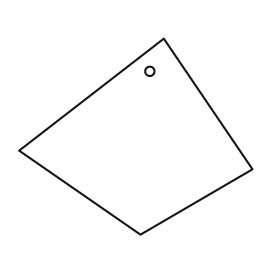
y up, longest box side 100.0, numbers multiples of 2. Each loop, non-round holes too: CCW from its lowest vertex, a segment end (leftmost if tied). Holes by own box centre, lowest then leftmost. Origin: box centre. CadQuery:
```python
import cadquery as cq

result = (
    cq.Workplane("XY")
    .moveTo(2.0, -42.0)
    .lineTo(50.0, -14.0)
    .lineTo(12.0, 42.0)
    .lineTo(-50.0, -6.0)
    .close()
    .moveTo(6.0, 28.0)
    .circle(2.0)
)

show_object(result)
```